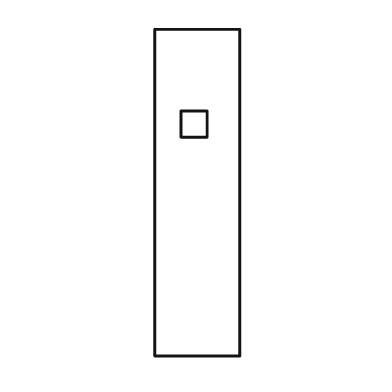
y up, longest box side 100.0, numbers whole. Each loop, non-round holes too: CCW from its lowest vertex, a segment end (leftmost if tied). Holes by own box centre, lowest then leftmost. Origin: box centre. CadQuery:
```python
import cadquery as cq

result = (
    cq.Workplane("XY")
    .moveTo(-13.0, -50.0)
    .lineTo(13.0, -50.0)
    .lineTo(13.0, 50.0)
    .lineTo(-13.0, 50.0)
    .close()
    .moveTo(-5.0, 17.0)
    .lineTo(3.0, 17.0)
    .lineTo(3.0, 25.0)
    .lineTo(-5.0, 25.0)
    .close()
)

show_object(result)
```